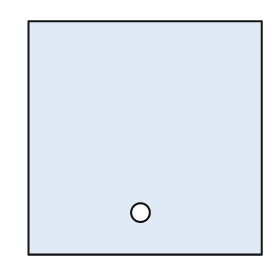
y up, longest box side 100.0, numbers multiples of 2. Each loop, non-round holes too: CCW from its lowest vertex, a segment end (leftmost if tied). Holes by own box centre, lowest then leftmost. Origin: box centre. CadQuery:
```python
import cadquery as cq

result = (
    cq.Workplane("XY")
    .moveTo(-50.0, -50.0)
    .lineTo(50.0, -50.0)
    .lineTo(50.0, 50.0)
    .lineTo(-50.0, 50.0)
    .close()
    .moveTo(-2.0, -32.0)
    .circle(4.0)
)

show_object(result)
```